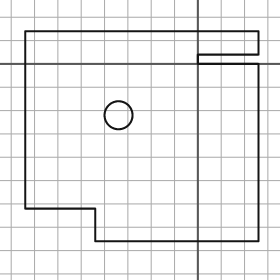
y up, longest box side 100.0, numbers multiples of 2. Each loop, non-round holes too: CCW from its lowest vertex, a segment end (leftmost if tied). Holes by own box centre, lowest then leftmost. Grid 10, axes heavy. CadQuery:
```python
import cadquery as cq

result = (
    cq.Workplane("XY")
    .moveTo(-44.0, -76.0)
    .lineTo(26.0, -76.0)
    .lineTo(26.0, 0.0)
    .lineTo(0.0, 0.0)
    .lineTo(0.0, 4.0)
    .lineTo(26.0, 4.0)
    .lineTo(26.0, 14.0)
    .lineTo(-74.0, 14.0)
    .lineTo(-74.0, -62.0)
    .lineTo(-44.0, -62.0)
    .close()
    .moveTo(-34.0, -22.0)
    .circle(6.0)
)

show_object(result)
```